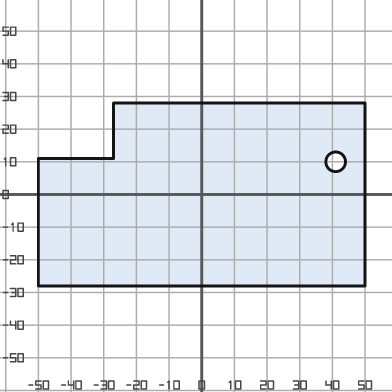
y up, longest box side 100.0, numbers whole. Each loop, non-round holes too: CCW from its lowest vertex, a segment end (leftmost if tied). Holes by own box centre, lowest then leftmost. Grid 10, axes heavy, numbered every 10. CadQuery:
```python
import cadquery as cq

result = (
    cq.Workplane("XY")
    .moveTo(-50.0, -28.0)
    .lineTo(50.0, -28.0)
    .lineTo(50.0, 28.0)
    .lineTo(-27.0, 28.0)
    .lineTo(-27.0, 11.0)
    .lineTo(-50.0, 11.0)
    .close()
    .moveTo(41.0, 10.0)
    .circle(3.0)
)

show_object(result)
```